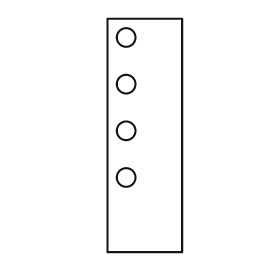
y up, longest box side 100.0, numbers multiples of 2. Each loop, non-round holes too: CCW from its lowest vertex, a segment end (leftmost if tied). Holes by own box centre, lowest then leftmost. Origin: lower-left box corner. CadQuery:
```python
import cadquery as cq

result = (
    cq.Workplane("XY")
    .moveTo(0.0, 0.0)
    .lineTo(32.0, 0.0)
    .lineTo(32.0, 100.0)
    .lineTo(0.0, 100.0)
    .close()
    .moveTo(8.0, 32.0)
    .circle(4.0)
    .moveTo(8.0, 52.0)
    .circle(4.0)
    .moveTo(8.0, 72.0)
    .circle(4.0)
    .moveTo(8.0, 92.0)
    .circle(4.0)
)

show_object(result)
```